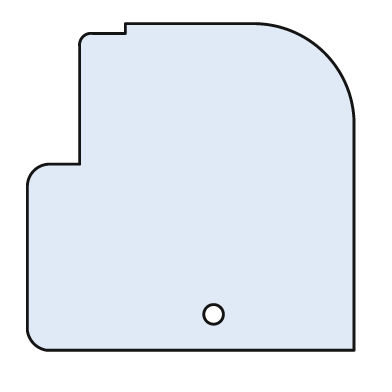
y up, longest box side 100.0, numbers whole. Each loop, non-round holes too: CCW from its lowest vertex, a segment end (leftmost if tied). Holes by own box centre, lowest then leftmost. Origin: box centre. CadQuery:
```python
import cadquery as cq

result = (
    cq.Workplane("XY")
    .moveTo(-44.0, -50.0)
    .lineTo(50.0, -50.0)
    .lineTo(50.0, 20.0)
    .threePointArc((41.0, 41.0), (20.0, 50.0))
    .lineTo(-20.0, 50.0)
    .lineTo(-20.0, 47.0)
    .lineTo(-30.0, 47.0)
    .threePointArc((-33.0, 46.0), (-34.0, 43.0))
    .lineTo(-34.0, 7.0)
    .lineTo(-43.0, 7.0)
    .threePointArc((-48.0, 5.0), (-50.0, 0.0))
    .lineTo(-50.0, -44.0)
    .threePointArc((-48.0, -48.0), (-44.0, -50.0))
    .close()
    .moveTo(7.0, -39.0)
    .circle(3.0)
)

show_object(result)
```